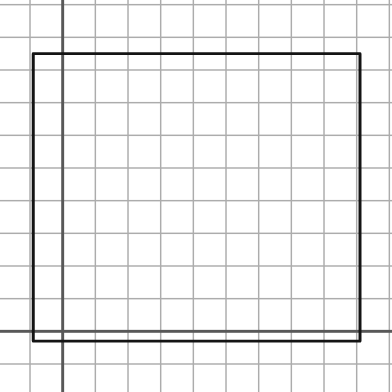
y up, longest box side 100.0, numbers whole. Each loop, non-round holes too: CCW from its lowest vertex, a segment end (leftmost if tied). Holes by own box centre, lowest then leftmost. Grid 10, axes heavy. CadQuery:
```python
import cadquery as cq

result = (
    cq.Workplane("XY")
    .moveTo(-9.0, -3.0)
    .lineTo(91.0, -3.0)
    .lineTo(91.0, 85.0)
    .lineTo(-9.0, 85.0)
    .close()
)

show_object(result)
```